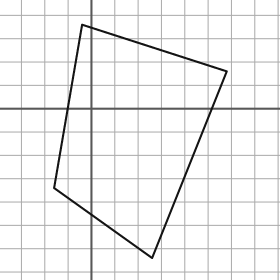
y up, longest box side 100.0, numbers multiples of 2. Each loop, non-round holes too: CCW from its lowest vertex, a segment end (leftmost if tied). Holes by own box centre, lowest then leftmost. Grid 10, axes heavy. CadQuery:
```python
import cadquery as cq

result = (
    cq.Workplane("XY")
    .moveTo(26.0, -64.0)
    .lineTo(58.0, 16.0)
    .lineTo(-4.0, 36.0)
    .lineTo(-16.0, -34.0)
    .close()
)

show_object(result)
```